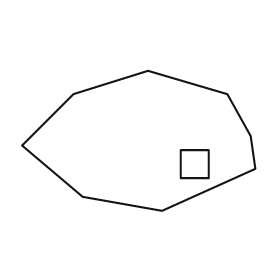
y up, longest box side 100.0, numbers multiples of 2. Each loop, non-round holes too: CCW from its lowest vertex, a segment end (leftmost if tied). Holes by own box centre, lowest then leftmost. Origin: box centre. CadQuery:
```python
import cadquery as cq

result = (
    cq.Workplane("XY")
    .moveTo(10.0, -30.0)
    .lineTo(50.0, -12.0)
    .lineTo(48.0, 2.0)
    .lineTo(38.0, 20.0)
    .lineTo(4.0, 30.0)
    .lineTo(-28.0, 20.0)
    .lineTo(-50.0, -2.0)
    .lineTo(-24.0, -24.0)
    .close()
    .moveTo(18.0, -16.0)
    .lineTo(30.0, -16.0)
    .lineTo(30.0, -4.0)
    .lineTo(18.0, -4.0)
    .close()
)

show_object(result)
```